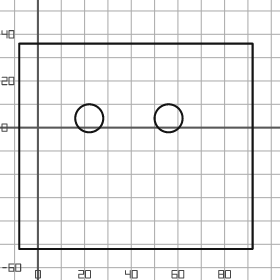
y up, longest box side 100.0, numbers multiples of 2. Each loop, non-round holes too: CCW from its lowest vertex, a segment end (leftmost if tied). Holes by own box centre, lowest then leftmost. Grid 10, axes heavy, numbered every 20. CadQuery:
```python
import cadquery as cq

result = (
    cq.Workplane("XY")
    .moveTo(-8.0, -52.0)
    .lineTo(92.0, -52.0)
    .lineTo(92.0, 36.0)
    .lineTo(-8.0, 36.0)
    .close()
    .moveTo(22.0, 4.0)
    .circle(6.0)
    .moveTo(56.0, 4.0)
    .circle(6.0)
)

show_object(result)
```